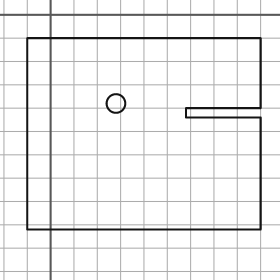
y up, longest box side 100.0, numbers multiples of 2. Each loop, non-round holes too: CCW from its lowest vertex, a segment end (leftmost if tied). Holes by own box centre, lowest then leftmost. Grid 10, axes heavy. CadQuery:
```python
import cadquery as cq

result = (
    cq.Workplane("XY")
    .moveTo(-10.0, -92.0)
    .lineTo(90.0, -92.0)
    .lineTo(90.0, -44.0)
    .lineTo(58.0, -44.0)
    .lineTo(58.0, -40.0)
    .lineTo(90.0, -40.0)
    .lineTo(90.0, -10.0)
    .lineTo(-10.0, -10.0)
    .close()
    .moveTo(28.0, -38.0)
    .circle(4.0)
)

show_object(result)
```